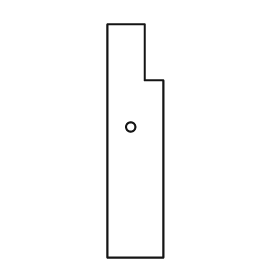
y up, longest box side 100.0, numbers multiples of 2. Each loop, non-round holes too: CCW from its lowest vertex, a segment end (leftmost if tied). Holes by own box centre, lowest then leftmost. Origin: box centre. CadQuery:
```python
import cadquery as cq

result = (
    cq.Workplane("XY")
    .moveTo(-12.0, -50.0)
    .lineTo(12.0, -50.0)
    .lineTo(12.0, 26.0)
    .lineTo(4.0, 26.0)
    .lineTo(4.0, 50.0)
    .lineTo(-12.0, 50.0)
    .close()
    .moveTo(-2.0, 6.0)
    .circle(2.0)
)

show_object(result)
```